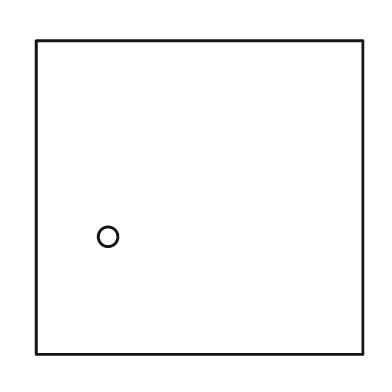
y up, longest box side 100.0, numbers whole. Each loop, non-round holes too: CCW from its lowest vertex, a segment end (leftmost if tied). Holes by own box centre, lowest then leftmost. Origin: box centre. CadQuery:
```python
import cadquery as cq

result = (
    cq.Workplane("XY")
    .moveTo(-50.0, -48.0)
    .lineTo(50.0, -48.0)
    .lineTo(50.0, 48.0)
    .lineTo(-50.0, 48.0)
    .close()
    .moveTo(-28.0, -12.0)
    .circle(3.0)
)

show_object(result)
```